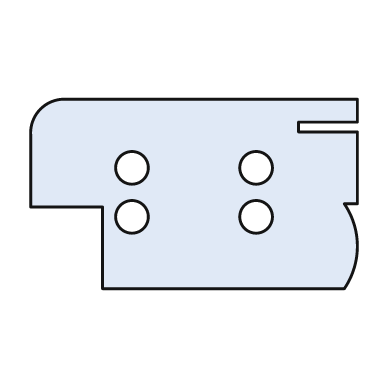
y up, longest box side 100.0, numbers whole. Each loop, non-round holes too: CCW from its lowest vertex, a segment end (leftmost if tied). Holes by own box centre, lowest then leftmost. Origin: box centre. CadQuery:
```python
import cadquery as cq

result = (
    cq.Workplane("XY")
    .moveTo(-28.0, -29.0)
    .lineTo(46.0, -29.0)
    .threePointArc((50.0, -16.0), (46.0, -3.0))
    .lineTo(50.0, -3.0)
    .lineTo(50.0, 19.0)
    .lineTo(32.0, 19.0)
    .lineTo(32.0, 22.0)
    .lineTo(50.0, 22.0)
    .lineTo(50.0, 29.0)
    .lineTo(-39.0, 29.0)
    .threePointArc((-47.0, 26.0), (-50.0, 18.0))
    .lineTo(-50.0, -4.0)
    .lineTo(-28.0, -4.0)
    .close()
    .moveTo(-19.0, -7.0)
    .circle(5.0)
    .moveTo(19.0, -7.0)
    .circle(5.0)
    .moveTo(-19.0, 8.0)
    .circle(5.0)
    .moveTo(19.0, 8.0)
    .circle(5.0)
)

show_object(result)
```